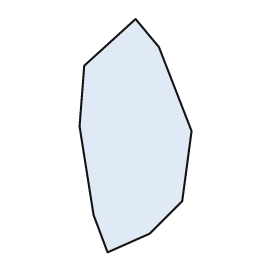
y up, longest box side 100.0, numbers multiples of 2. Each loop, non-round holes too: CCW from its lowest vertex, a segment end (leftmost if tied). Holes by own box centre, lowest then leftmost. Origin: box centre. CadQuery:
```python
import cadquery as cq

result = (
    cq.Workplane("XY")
    .moveTo(-12.0, -50.0)
    .lineTo(6.0, -42.0)
    .lineTo(20.0, -28.0)
    .lineTo(24.0, 2.0)
    .lineTo(10.0, 38.0)
    .lineTo(0.0, 50.0)
    .lineTo(-22.0, 30.0)
    .lineTo(-24.0, 4.0)
    .lineTo(-18.0, -34.0)
    .close()
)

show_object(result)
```